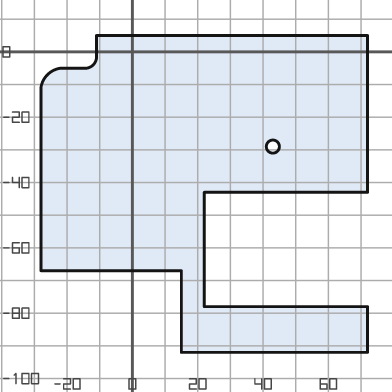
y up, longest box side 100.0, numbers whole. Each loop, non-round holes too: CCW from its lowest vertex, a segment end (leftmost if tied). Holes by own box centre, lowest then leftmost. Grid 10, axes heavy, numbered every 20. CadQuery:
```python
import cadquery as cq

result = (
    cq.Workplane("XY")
    .moveTo(15.0, -92.0)
    .lineTo(72.0, -92.0)
    .lineTo(72.0, -78.0)
    .lineTo(22.0, -78.0)
    .lineTo(22.0, -43.0)
    .lineTo(72.0, -43.0)
    .lineTo(72.0, 5.0)
    .lineTo(-11.0, 5.0)
    .lineTo(-11.0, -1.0)
    .threePointArc((-12.0, -4.0), (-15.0, -5.0))
    .lineTo(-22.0, -5.0)
    .threePointArc((-26.0, -7.0), (-28.0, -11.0))
    .lineTo(-28.0, -67.0)
    .lineTo(15.0, -67.0)
    .close()
    .moveTo(43.0, -29.0)
    .circle(2.0)
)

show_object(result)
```